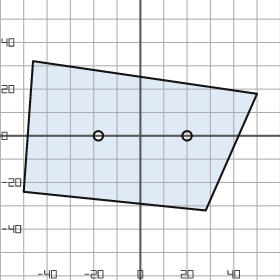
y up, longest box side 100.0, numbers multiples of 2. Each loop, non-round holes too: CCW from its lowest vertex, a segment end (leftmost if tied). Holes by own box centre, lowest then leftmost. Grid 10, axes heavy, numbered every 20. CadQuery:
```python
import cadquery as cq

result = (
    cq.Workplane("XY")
    .moveTo(28.0, -32.0)
    .lineTo(50.0, 18.0)
    .lineTo(-46.0, 32.0)
    .lineTo(-50.0, -24.0)
    .close()
    .moveTo(-18.0, 0.0)
    .circle(2.0)
    .moveTo(20.0, 0.0)
    .circle(2.0)
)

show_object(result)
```